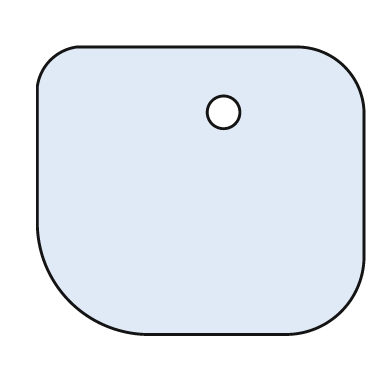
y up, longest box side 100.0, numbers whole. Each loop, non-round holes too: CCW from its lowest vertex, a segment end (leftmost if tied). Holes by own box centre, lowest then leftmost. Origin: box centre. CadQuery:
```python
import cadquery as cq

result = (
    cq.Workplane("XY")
    .moveTo(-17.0, -44.0)
    .lineTo(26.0, -44.0)
    .threePointArc((43.0, -37.0), (50.0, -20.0))
    .lineTo(50.0, 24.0)
    .threePointArc((44.0, 38.0), (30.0, 44.0))
    .lineTo(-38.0, 44.0)
    .threePointArc((-46.0, 40.0), (-50.0, 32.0))
    .lineTo(-50.0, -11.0)
    .threePointArc((-40.0, -34.0), (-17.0, -44.0))
    .close()
    .moveTo(7.0, 24.0)
    .circle(5.0)
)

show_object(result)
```